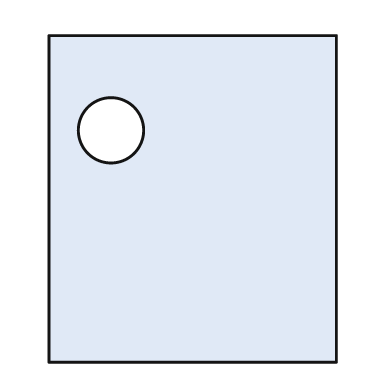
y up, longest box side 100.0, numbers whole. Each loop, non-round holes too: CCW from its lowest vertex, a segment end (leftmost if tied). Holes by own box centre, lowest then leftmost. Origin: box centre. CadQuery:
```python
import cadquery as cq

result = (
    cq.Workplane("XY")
    .moveTo(-44.0, -50.0)
    .lineTo(44.0, -50.0)
    .lineTo(44.0, 50.0)
    .lineTo(-44.0, 50.0)
    .close()
    .moveTo(-25.0, 21.0)
    .circle(10.0)
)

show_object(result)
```